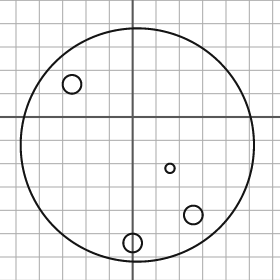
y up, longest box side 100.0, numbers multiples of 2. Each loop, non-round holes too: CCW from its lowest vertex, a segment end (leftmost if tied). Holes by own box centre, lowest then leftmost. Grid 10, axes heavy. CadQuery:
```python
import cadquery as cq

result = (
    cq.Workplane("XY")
    .moveTo(2.0, -12.0)
    .circle(50.0)
    .moveTo(0.0, -54.0)
    .circle(4.0)
    .moveTo(26.0, -42.0)
    .circle(4.0)
    .moveTo(16.0, -22.0)
    .circle(2.0)
    .moveTo(-26.0, 14.0)
    .circle(4.0)
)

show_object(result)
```